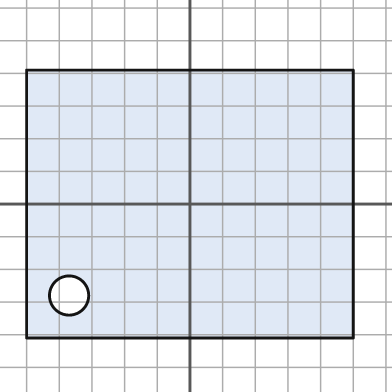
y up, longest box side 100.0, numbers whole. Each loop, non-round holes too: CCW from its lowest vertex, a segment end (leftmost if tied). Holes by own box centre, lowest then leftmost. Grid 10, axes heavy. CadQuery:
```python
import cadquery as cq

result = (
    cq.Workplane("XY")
    .moveTo(-50.0, -41.0)
    .lineTo(50.0, -41.0)
    .lineTo(50.0, 41.0)
    .lineTo(-50.0, 41.0)
    .close()
    .moveTo(-37.0, -28.0)
    .circle(6.0)
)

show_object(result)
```